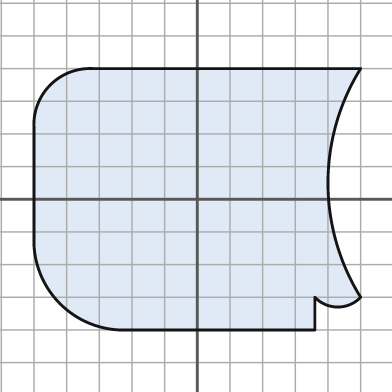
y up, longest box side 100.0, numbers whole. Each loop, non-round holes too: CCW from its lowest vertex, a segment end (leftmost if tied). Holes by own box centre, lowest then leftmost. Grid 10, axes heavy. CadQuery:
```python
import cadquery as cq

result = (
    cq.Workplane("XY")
    .moveTo(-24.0, -40.0)
    .lineTo(36.0, -40.0)
    .lineTo(36.0, -30.0)
    .threePointArc((43.0, -33.0), (50.0, -30.0))
    .threePointArc((40.0, 5.0), (50.0, 40.0))
    .lineTo(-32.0, 40.0)
    .threePointArc((-45.0, 35.0), (-50.0, 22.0))
    .lineTo(-50.0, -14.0)
    .threePointArc((-42.0, -32.0), (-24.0, -40.0))
    .close()
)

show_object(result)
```